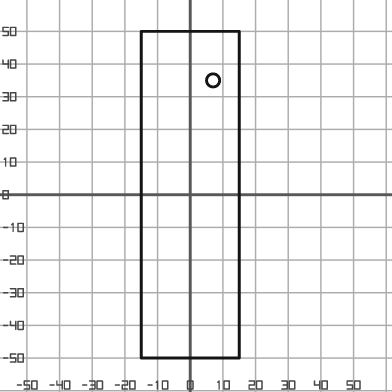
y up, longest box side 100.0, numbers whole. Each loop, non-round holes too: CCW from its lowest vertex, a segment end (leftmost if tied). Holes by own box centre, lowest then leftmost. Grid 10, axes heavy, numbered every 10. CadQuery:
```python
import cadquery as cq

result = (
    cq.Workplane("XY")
    .moveTo(-15.0, -50.0)
    .lineTo(15.0, -50.0)
    .lineTo(15.0, 50.0)
    .lineTo(-15.0, 50.0)
    .close()
    .moveTo(7.0, 35.0)
    .circle(2.0)
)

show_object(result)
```